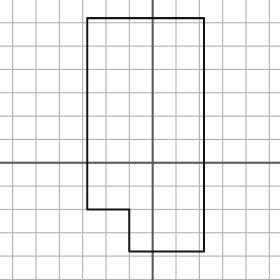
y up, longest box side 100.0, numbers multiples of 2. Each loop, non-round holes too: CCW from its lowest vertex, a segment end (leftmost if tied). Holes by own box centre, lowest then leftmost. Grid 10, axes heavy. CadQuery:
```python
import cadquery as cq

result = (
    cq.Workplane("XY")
    .moveTo(-10.0, -38.0)
    .lineTo(22.0, -38.0)
    .lineTo(22.0, 62.0)
    .lineTo(-28.0, 62.0)
    .lineTo(-28.0, -20.0)
    .lineTo(-10.0, -20.0)
    .close()
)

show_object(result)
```